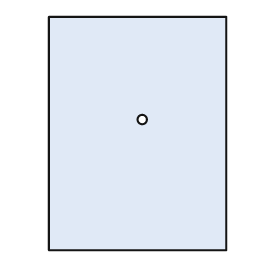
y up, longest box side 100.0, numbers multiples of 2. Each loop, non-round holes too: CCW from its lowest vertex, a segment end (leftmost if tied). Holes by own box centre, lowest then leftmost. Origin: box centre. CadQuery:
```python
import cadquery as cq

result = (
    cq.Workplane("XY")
    .moveTo(-38.0, -50.0)
    .lineTo(38.0, -50.0)
    .lineTo(38.0, 50.0)
    .lineTo(-38.0, 50.0)
    .close()
    .moveTo(2.0, 6.0)
    .circle(2.0)
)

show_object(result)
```